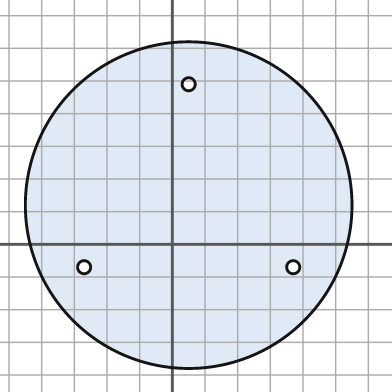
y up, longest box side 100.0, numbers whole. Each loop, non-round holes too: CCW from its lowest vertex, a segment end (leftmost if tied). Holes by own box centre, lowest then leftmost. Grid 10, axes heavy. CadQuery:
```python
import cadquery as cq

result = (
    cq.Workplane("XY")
    .moveTo(5.0, 12.0)
    .circle(50.0)
    .moveTo(-27.0, -7.0)
    .circle(2.0)
    .moveTo(37.0, -7.0)
    .circle(2.0)
    .moveTo(5.0, 49.0)
    .circle(2.0)
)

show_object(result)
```